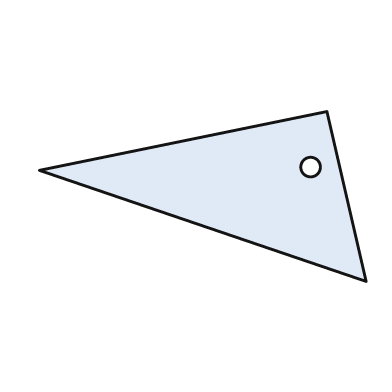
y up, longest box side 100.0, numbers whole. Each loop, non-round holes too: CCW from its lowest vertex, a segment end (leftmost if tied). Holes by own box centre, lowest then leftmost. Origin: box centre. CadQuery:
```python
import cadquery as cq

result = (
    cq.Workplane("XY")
    .moveTo(50.0, -26.0)
    .lineTo(38.0, 26.0)
    .lineTo(-50.0, 8.0)
    .close()
    .moveTo(33.0, 9.0)
    .circle(3.0)
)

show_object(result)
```